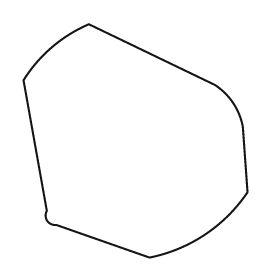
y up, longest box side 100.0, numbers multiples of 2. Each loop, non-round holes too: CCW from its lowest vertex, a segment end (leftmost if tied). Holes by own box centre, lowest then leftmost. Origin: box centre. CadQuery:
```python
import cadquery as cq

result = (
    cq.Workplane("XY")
    .moveTo(6.0, -50.0)
    .threePointArc((30.0, -40.0), (48.0, -22.0))
    .lineTo(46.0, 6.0)
    .threePointArc((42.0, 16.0), (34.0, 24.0))
    .lineTo(-20.0, 50.0)
    .threePointArc((-36.0, 40.0), (-48.0, 26.0))
    .lineTo(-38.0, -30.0)
    .threePointArc((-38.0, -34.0), (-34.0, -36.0))
    .close()
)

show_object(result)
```